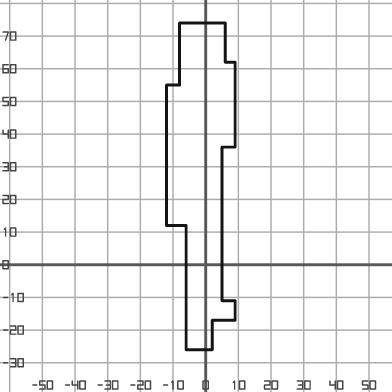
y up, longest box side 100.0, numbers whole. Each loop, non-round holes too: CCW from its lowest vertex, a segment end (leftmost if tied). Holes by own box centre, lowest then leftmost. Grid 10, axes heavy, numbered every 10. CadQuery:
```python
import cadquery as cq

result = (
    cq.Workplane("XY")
    .moveTo(-6.0, -26.0)
    .lineTo(2.0, -26.0)
    .lineTo(2.0, -17.0)
    .lineTo(9.0, -17.0)
    .lineTo(9.0, -11.0)
    .lineTo(5.0, -11.0)
    .lineTo(5.0, 36.0)
    .lineTo(9.0, 36.0)
    .lineTo(9.0, 62.0)
    .lineTo(6.0, 62.0)
    .lineTo(6.0, 74.0)
    .lineTo(-8.0, 74.0)
    .lineTo(-8.0, 55.0)
    .lineTo(-12.0, 55.0)
    .lineTo(-12.0, 12.0)
    .lineTo(-6.0, 12.0)
    .close()
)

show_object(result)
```